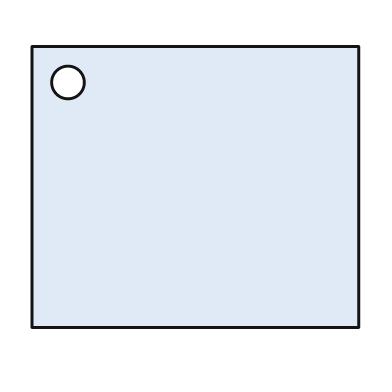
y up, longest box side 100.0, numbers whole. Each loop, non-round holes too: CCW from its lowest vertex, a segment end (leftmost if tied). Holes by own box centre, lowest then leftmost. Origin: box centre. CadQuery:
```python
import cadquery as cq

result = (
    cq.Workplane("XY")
    .moveTo(-50.0, -43.0)
    .lineTo(50.0, -43.0)
    .lineTo(50.0, 43.0)
    .lineTo(-50.0, 43.0)
    .close()
    .moveTo(-39.0, 32.0)
    .circle(5.0)
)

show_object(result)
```